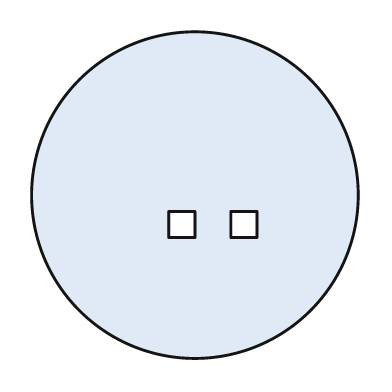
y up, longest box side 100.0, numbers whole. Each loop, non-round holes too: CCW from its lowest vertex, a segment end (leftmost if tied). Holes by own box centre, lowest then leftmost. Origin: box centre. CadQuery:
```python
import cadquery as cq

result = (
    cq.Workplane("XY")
    .moveTo(0.0, 0.0)
    .circle(50.0)
    .moveTo(-8.0, -13.0)
    .lineTo(0.0, -13.0)
    .lineTo(0.0, -5.0)
    .lineTo(-8.0, -5.0)
    .close()
    .moveTo(11.0, -13.0)
    .lineTo(19.0, -13.0)
    .lineTo(19.0, -5.0)
    .lineTo(11.0, -5.0)
    .close()
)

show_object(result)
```